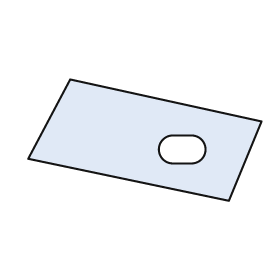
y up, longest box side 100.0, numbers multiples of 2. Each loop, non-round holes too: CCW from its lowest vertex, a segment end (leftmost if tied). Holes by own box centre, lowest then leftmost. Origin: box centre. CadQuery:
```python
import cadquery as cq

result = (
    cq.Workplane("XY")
    .moveTo(36.0, -26.0)
    .lineTo(50.0, 8.0)
    .lineTo(-32.0, 26.0)
    .lineTo(-50.0, -8.0)
    .close()
    .moveTo(12.0, -10.0)
    .lineTo(20.0, -10.0)
    .threePointArc((26.0, -4.0), (20.0, 2.0))
    .lineTo(12.0, 2.0)
    .threePointArc((6.0, -4.0), (12.0, -10.0))
    .close()
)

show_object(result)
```